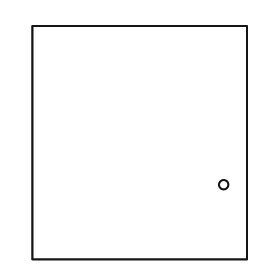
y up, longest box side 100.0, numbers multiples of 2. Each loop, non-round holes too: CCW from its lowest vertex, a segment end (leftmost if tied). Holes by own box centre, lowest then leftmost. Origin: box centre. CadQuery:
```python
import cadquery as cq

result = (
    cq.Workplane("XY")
    .moveTo(-46.0, -50.0)
    .lineTo(46.0, -50.0)
    .lineTo(46.0, 50.0)
    .lineTo(-46.0, 50.0)
    .close()
    .moveTo(36.0, -18.0)
    .circle(2.0)
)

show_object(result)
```